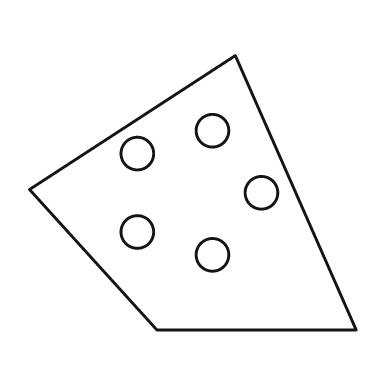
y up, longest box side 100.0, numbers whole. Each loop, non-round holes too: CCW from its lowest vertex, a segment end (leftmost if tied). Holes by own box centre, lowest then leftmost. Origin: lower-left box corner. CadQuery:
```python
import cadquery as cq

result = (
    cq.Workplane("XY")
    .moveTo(39.0, 0.0)
    .lineTo(100.0, 0.0)
    .lineTo(63.0, 84.0)
    .lineTo(0.0, 43.0)
    .close()
    .moveTo(56.0, 23.0)
    .circle(5.0)
    .moveTo(33.0, 30.0)
    .circle(5.0)
    .moveTo(71.0, 42.0)
    .circle(5.0)
    .moveTo(33.0, 54.0)
    .circle(5.0)
    .moveTo(56.0, 61.0)
    .circle(5.0)
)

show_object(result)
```